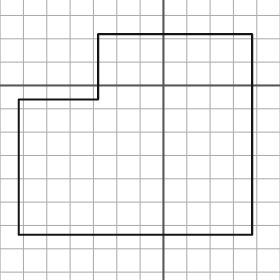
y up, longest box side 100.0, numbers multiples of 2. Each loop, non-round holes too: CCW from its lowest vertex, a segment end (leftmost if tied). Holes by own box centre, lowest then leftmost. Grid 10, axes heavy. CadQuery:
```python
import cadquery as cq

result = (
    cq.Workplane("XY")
    .moveTo(-62.0, -64.0)
    .lineTo(38.0, -64.0)
    .lineTo(38.0, 22.0)
    .lineTo(-28.0, 22.0)
    .lineTo(-28.0, -6.0)
    .lineTo(-62.0, -6.0)
    .close()
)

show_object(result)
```